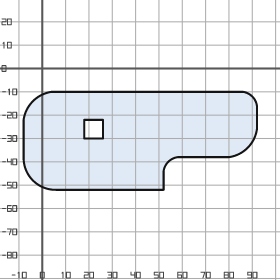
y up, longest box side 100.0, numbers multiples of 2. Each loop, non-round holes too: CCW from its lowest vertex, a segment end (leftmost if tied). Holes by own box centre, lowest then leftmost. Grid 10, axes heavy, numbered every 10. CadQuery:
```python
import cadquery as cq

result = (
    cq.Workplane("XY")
    .moveTo(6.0, -52.0)
    .lineTo(52.0, -52.0)
    .lineTo(52.0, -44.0)
    .threePointArc((54.0, -40.0), (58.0, -38.0))
    .lineTo(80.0, -38.0)
    .threePointArc((88.0, -34.0), (92.0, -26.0))
    .lineTo(92.0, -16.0)
    .threePointArc((90.0, -12.0), (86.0, -10.0))
    .lineTo(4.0, -10.0)
    .threePointArc((-4.0, -14.0), (-8.0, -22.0))
    .lineTo(-8.0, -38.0)
    .threePointArc((-4.0, -48.0), (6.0, -52.0))
    .close()
    .moveTo(18.0, -30.0)
    .lineTo(26.0, -30.0)
    .lineTo(26.0, -22.0)
    .lineTo(18.0, -22.0)
    .close()
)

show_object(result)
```